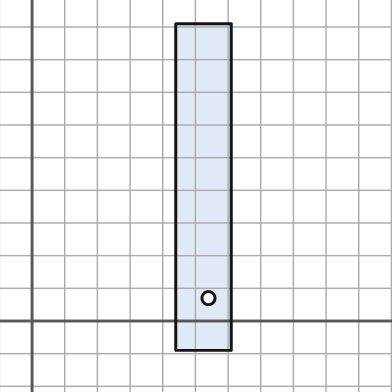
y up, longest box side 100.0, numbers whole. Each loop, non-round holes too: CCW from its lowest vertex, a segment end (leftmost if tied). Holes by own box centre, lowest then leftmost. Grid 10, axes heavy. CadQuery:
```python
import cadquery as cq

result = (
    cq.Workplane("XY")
    .moveTo(44.0, -9.0)
    .lineTo(61.0, -9.0)
    .lineTo(61.0, 91.0)
    .lineTo(44.0, 91.0)
    .close()
    .moveTo(54.0, 7.0)
    .circle(2.0)
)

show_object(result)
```